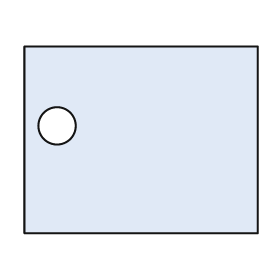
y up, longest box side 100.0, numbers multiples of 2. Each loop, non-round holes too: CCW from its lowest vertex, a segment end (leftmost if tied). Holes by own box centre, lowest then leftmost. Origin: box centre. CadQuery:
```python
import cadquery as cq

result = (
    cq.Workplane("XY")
    .moveTo(-50.0, -40.0)
    .lineTo(50.0, -40.0)
    .lineTo(50.0, 40.0)
    .lineTo(-50.0, 40.0)
    .close()
    .moveTo(-36.0, 6.0)
    .circle(8.0)
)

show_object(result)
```